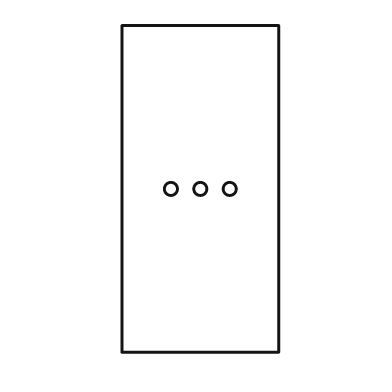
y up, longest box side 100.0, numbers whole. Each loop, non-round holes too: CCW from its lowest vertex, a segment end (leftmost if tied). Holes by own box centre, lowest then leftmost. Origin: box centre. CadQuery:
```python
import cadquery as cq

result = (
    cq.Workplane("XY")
    .moveTo(-24.0, -50.0)
    .lineTo(24.0, -50.0)
    .lineTo(24.0, 50.0)
    .lineTo(-24.0, 50.0)
    .close()
    .moveTo(-9.0, 0.0)
    .circle(2.0)
    .moveTo(0.0, 0.0)
    .circle(2.0)
    .moveTo(9.0, 0.0)
    .circle(2.0)
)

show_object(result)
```